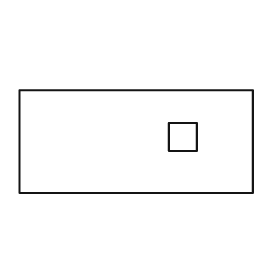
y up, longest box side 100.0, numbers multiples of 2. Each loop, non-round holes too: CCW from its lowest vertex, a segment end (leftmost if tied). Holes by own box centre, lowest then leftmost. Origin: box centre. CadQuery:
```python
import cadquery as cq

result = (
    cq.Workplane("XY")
    .moveTo(-50.0, -22.0)
    .lineTo(50.0, -22.0)
    .lineTo(50.0, 22.0)
    .lineTo(-50.0, 22.0)
    .close()
    .moveTo(14.0, -4.0)
    .lineTo(26.0, -4.0)
    .lineTo(26.0, 8.0)
    .lineTo(14.0, 8.0)
    .close()
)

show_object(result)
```